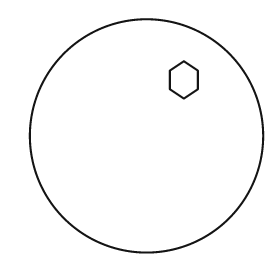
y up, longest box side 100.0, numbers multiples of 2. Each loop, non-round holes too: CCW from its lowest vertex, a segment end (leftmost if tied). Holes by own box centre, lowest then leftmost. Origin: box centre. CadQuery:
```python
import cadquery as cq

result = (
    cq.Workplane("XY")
    .moveTo(0.0, 0.0)
    .circle(50.0)
    .moveTo(16.0, 16.0)
    .lineTo(22.0, 20.0)
    .lineTo(22.0, 28.0)
    .lineTo(16.0, 32.0)
    .lineTo(10.0, 28.0)
    .lineTo(10.0, 20.0)
    .close()
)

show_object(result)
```